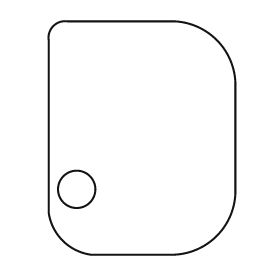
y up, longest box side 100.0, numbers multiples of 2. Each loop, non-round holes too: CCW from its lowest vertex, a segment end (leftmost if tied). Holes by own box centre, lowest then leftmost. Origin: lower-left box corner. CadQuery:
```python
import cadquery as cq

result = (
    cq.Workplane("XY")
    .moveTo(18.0, 0.0)
    .lineTo(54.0, 0.0)
    .threePointArc((72.0, 8.0), (80.0, 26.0))
    .lineTo(80.0, 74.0)
    .threePointArc((72.0, 92.0), (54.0, 100.0))
    .lineTo(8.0, 100.0)
    .threePointArc((2.0, 98.0), (0.0, 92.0))
    .lineTo(0.0, 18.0)
    .threePointArc((6.0, 6.0), (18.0, 0.0))
    .close()
    .moveTo(12.0, 28.0)
    .circle(8.0)
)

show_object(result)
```